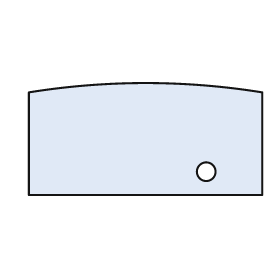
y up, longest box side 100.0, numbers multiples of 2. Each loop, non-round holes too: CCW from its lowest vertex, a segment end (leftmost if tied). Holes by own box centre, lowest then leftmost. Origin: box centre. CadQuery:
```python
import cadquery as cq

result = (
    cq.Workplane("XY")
    .moveTo(-50.0, -24.0)
    .lineTo(50.0, -24.0)
    .lineTo(50.0, 20.0)
    .threePointArc((0.0, 24.0), (-50.0, 20.0))
    .close()
    .moveTo(26.0, -14.0)
    .circle(4.0)
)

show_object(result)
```